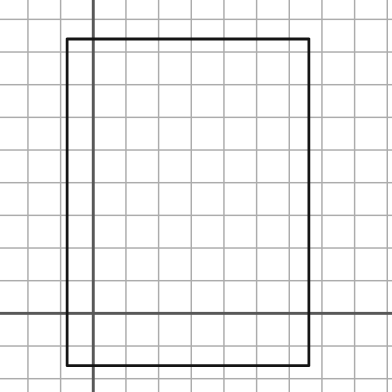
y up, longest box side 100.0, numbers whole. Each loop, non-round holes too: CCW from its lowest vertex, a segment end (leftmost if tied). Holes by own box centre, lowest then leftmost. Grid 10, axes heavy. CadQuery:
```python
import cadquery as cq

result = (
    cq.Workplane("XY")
    .moveTo(-8.0, -16.0)
    .lineTo(66.0, -16.0)
    .lineTo(66.0, 84.0)
    .lineTo(-8.0, 84.0)
    .close()
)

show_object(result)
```